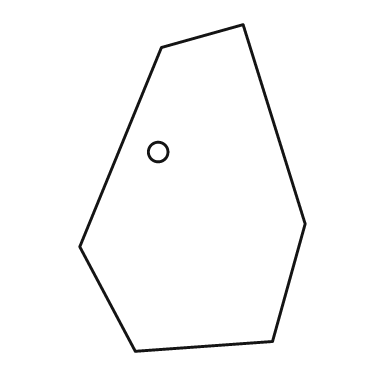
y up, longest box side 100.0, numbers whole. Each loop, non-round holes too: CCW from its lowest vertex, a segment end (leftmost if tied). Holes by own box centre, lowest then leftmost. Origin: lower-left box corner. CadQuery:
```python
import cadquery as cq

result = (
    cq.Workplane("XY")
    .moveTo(17.0, 0.0)
    .lineTo(59.0, 3.0)
    .lineTo(69.0, 39.0)
    .lineTo(50.0, 100.0)
    .lineTo(25.0, 93.0)
    .lineTo(0.0, 32.0)
    .close()
    .moveTo(24.0, 61.0)
    .circle(3.0)
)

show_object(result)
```